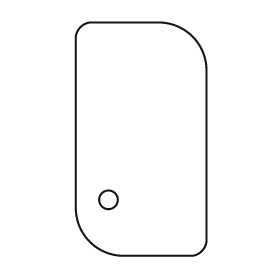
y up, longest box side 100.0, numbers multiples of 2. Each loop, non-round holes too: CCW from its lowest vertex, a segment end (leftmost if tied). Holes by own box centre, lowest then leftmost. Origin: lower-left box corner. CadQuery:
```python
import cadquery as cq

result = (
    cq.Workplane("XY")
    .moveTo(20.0, 0.0)
    .lineTo(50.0, 0.0)
    .threePointArc((54.0, 2.0), (56.0, 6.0))
    .lineTo(56.0, 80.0)
    .threePointArc((50.0, 94.0), (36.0, 100.0))
    .lineTo(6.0, 100.0)
    .threePointArc((2.0, 98.0), (0.0, 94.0))
    .lineTo(0.0, 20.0)
    .threePointArc((6.0, 6.0), (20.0, 0.0))
    .close()
    .moveTo(14.0, 24.0)
    .circle(4.0)
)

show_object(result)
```